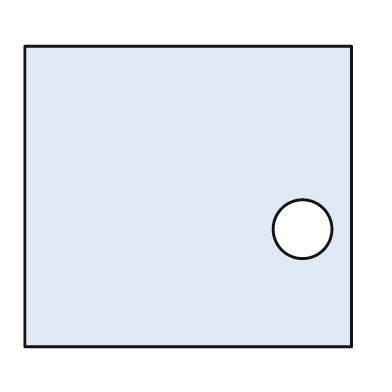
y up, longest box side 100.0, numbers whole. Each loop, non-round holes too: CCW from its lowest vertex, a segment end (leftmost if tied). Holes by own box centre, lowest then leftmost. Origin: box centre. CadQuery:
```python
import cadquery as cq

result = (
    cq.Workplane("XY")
    .moveTo(-50.0, -46.0)
    .lineTo(50.0, -46.0)
    .lineTo(50.0, 46.0)
    .lineTo(-50.0, 46.0)
    .close()
    .moveTo(35.0, -10.0)
    .circle(9.0)
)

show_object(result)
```